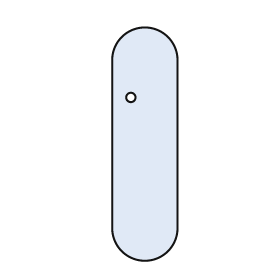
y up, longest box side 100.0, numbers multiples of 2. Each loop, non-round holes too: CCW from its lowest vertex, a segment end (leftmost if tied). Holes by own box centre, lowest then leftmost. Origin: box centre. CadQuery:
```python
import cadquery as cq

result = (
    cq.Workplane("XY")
    .moveTo(-14.0, -36.0)
    .threePointArc((0.0, -50.0), (14.0, -36.0))
    .lineTo(14.0, 36.0)
    .threePointArc((0.0, 50.0), (-14.0, 36.0))
    .close()
    .moveTo(-6.0, 20.0)
    .circle(2.0)
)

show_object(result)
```